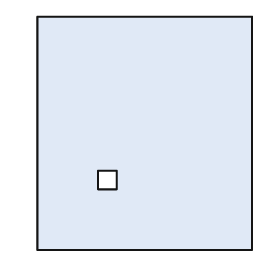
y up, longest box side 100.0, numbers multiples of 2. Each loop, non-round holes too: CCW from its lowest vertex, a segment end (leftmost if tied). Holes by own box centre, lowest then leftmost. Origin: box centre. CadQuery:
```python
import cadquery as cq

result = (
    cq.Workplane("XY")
    .moveTo(-46.0, -50.0)
    .lineTo(46.0, -50.0)
    .lineTo(46.0, 50.0)
    .lineTo(-46.0, 50.0)
    .close()
    .moveTo(-20.0, -24.0)
    .lineTo(-12.0, -24.0)
    .lineTo(-12.0, -16.0)
    .lineTo(-20.0, -16.0)
    .close()
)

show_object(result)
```